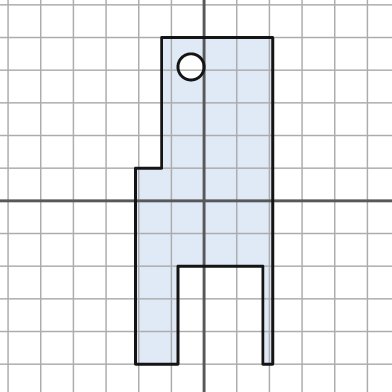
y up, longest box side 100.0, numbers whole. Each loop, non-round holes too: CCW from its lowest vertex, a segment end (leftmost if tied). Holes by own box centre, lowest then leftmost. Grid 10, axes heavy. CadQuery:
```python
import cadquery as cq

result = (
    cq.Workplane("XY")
    .moveTo(-21.0, -50.0)
    .lineTo(-8.0, -50.0)
    .lineTo(-8.0, -20.0)
    .lineTo(18.0, -20.0)
    .lineTo(18.0, -50.0)
    .lineTo(21.0, -50.0)
    .lineTo(21.0, 50.0)
    .lineTo(-13.0, 50.0)
    .lineTo(-13.0, 10.0)
    .lineTo(-21.0, 10.0)
    .close()
    .moveTo(-4.0, 41.0)
    .circle(4.0)
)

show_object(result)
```